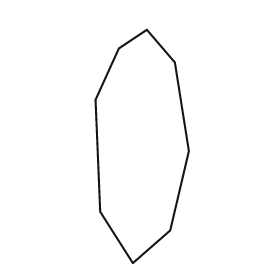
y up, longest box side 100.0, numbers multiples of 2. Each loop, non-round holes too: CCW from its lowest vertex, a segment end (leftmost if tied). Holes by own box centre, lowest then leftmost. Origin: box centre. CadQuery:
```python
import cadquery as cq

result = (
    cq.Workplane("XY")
    .moveTo(-4.0, -50.0)
    .lineTo(12.0, -36.0)
    .lineTo(20.0, -2.0)
    .lineTo(14.0, 36.0)
    .lineTo(2.0, 50.0)
    .lineTo(-10.0, 42.0)
    .lineTo(-20.0, 20.0)
    .lineTo(-18.0, -28.0)
    .close()
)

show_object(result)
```